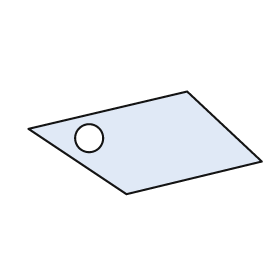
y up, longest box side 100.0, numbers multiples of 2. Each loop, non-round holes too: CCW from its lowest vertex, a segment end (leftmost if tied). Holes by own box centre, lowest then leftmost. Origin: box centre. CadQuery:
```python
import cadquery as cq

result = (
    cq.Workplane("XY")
    .moveTo(-8.0, -22.0)
    .lineTo(50.0, -8.0)
    .lineTo(18.0, 22.0)
    .lineTo(-50.0, 6.0)
    .close()
    .moveTo(-24.0, 2.0)
    .circle(6.0)
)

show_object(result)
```